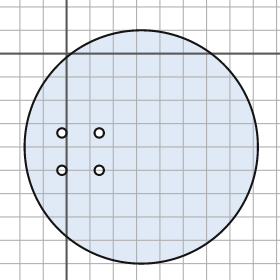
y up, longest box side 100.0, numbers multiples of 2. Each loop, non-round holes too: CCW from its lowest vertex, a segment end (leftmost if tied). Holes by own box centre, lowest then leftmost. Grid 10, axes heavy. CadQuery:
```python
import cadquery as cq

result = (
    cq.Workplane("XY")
    .moveTo(32.0, -40.0)
    .circle(50.0)
    .moveTo(-2.0, -50.0)
    .circle(2.0)
    .moveTo(14.0, -50.0)
    .circle(2.0)
    .moveTo(-2.0, -34.0)
    .circle(2.0)
    .moveTo(14.0, -34.0)
    .circle(2.0)
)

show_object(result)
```